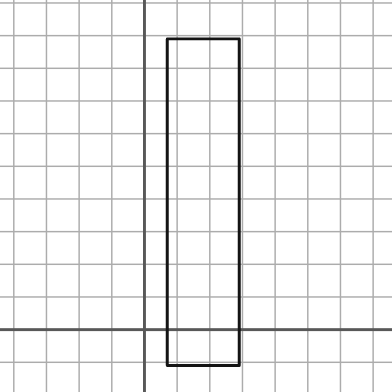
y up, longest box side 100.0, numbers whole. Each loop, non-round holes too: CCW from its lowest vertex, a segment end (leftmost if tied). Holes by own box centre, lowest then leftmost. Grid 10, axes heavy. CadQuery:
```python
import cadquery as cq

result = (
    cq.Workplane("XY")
    .moveTo(7.0, -11.0)
    .lineTo(29.0, -11.0)
    .lineTo(29.0, 89.0)
    .lineTo(7.0, 89.0)
    .close()
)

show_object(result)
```